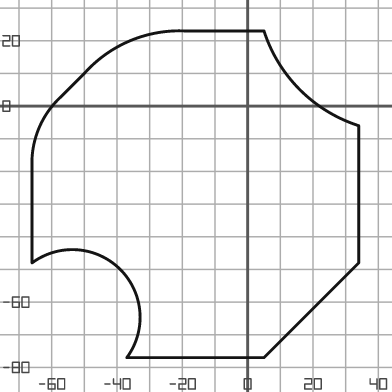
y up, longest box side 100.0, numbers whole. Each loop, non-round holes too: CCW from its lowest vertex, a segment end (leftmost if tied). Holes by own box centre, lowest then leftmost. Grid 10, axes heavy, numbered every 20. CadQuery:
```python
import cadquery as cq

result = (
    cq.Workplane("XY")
    .moveTo(-37.0, -77.0)
    .lineTo(5.0, -77.0)
    .lineTo(34.0, -48.0)
    .lineTo(34.0, -6.0)
    .threePointArc((16.0, 5.0), (5.0, 23.0))
    .lineTo(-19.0, 23.0)
    .threePointArc((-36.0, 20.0), (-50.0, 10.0))
    .lineTo(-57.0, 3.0)
    .threePointArc((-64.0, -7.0), (-66.0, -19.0))
    .lineTo(-66.0, -48.0)
    .threePointArc((-39.0, -50.0), (-37.0, -77.0))
    .close()
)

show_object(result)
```